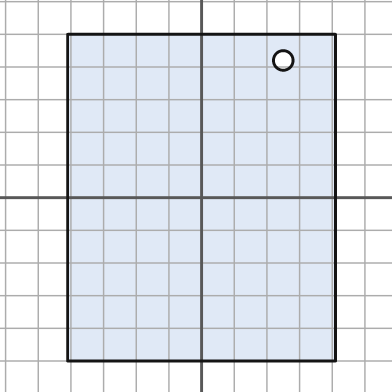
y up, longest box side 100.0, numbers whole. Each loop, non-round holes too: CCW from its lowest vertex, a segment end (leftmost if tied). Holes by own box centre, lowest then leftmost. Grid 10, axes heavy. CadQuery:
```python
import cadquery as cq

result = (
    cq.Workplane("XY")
    .moveTo(-41.0, -50.0)
    .lineTo(41.0, -50.0)
    .lineTo(41.0, 50.0)
    .lineTo(-41.0, 50.0)
    .close()
    .moveTo(25.0, 42.0)
    .circle(3.0)
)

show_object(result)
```